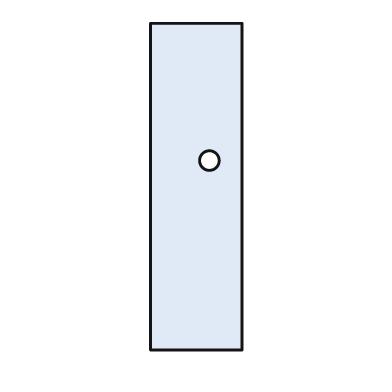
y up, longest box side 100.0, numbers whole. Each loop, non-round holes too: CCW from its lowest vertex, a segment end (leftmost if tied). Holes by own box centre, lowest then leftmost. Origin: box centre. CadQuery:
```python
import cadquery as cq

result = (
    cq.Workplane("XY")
    .moveTo(-14.0, -50.0)
    .lineTo(14.0, -50.0)
    .lineTo(14.0, 50.0)
    .lineTo(-14.0, 50.0)
    .close()
    .moveTo(4.0, 8.0)
    .circle(3.0)
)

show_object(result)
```